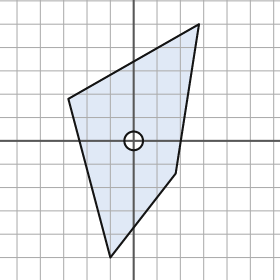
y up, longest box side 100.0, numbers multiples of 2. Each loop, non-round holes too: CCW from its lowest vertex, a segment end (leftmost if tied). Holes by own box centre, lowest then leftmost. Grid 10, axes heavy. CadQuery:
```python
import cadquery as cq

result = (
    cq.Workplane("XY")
    .moveTo(-10.0, -50.0)
    .lineTo(18.0, -14.0)
    .lineTo(28.0, 50.0)
    .lineTo(-28.0, 18.0)
    .close()
    .moveTo(0.0, 0.0)
    .circle(4.0)
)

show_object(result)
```